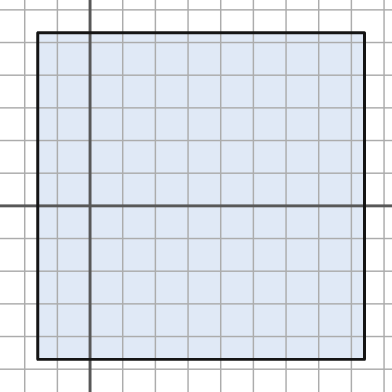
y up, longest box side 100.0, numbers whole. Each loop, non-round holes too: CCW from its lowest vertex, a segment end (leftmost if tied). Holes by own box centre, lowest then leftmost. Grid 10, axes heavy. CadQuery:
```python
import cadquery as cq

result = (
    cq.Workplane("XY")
    .moveTo(-16.0, -47.0)
    .lineTo(84.0, -47.0)
    .lineTo(84.0, 53.0)
    .lineTo(-16.0, 53.0)
    .close()
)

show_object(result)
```